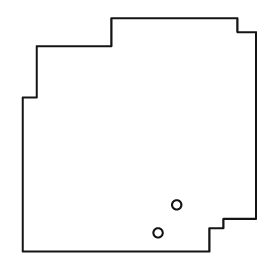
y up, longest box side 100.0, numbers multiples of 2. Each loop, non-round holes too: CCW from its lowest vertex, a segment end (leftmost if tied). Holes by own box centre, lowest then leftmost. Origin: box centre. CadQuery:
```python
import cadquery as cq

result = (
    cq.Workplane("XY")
    .moveTo(-50.0, -50.0)
    .lineTo(30.0, -50.0)
    .lineTo(30.0, -40.0)
    .lineTo(36.0, -40.0)
    .lineTo(36.0, -36.0)
    .lineTo(50.0, -36.0)
    .lineTo(50.0, 44.0)
    .lineTo(42.0, 44.0)
    .lineTo(42.0, 50.0)
    .lineTo(-12.0, 50.0)
    .lineTo(-12.0, 38.0)
    .lineTo(-44.0, 38.0)
    .lineTo(-44.0, 16.0)
    .lineTo(-50.0, 16.0)
    .close()
    .moveTo(8.0, -42.0)
    .circle(2.0)
    .moveTo(16.0, -30.0)
    .circle(2.0)
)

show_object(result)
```